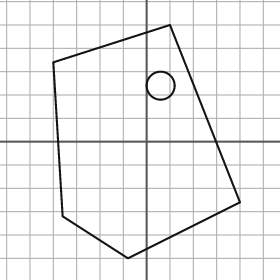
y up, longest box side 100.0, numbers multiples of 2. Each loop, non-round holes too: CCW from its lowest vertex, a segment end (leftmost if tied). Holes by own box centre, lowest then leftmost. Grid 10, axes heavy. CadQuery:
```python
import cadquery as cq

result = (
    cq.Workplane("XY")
    .moveTo(-8.0, -50.0)
    .lineTo(40.0, -26.0)
    .lineTo(10.0, 50.0)
    .lineTo(-40.0, 34.0)
    .lineTo(-36.0, -32.0)
    .close()
    .moveTo(6.0, 24.0)
    .circle(6.0)
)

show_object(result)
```